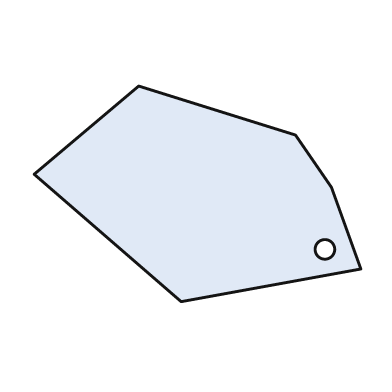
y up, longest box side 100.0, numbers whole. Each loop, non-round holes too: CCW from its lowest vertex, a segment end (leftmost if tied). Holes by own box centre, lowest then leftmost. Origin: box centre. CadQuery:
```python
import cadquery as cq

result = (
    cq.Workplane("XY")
    .moveTo(-5.0, -33.0)
    .lineTo(50.0, -23.0)
    .lineTo(41.0, 2.0)
    .lineTo(30.0, 18.0)
    .lineTo(-18.0, 33.0)
    .lineTo(-50.0, 6.0)
    .close()
    .moveTo(39.0, -17.0)
    .circle(3.0)
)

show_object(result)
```